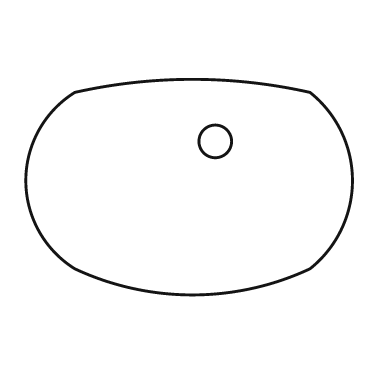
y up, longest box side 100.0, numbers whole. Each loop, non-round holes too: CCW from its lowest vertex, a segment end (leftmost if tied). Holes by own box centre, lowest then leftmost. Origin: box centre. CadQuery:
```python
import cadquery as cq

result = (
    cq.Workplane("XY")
    .moveTo(-35.0, -25.0)
    .threePointArc((1.0, -33.0), (37.0, -25.0))
    .threePointArc((50.0, 2.0), (37.0, 29.0))
    .threePointArc((1.0, 33.0), (-35.0, 29.0))
    .threePointArc((-50.0, 2.0), (-35.0, -25.0))
    .close()
    .moveTo(8.0, 14.0)
    .circle(5.0)
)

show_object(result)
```